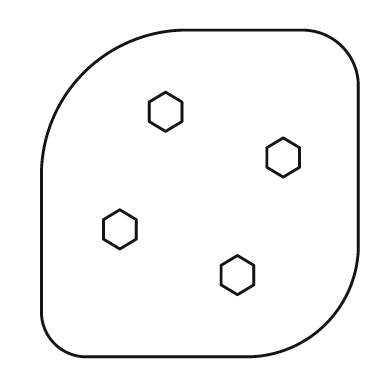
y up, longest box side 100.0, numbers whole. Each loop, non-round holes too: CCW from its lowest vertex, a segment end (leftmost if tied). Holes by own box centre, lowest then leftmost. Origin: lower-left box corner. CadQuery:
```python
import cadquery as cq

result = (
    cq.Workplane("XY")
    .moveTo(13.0, 0.0)
    .lineTo(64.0, 0.0)
    .threePointArc((87.0, 10.0), (97.0, 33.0))
    .lineTo(97.0, 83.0)
    .threePointArc((92.0, 95.0), (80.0, 100.0))
    .lineTo(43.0, 100.0)
    .threePointArc((13.0, 87.0), (0.0, 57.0))
    .lineTo(0.0, 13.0)
    .threePointArc((4.0, 4.0), (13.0, 0.0))
    .close()
    .moveTo(60.0, 19.0)
    .lineTo(65.0, 22.0)
    .lineTo(65.0, 28.0)
    .lineTo(60.0, 31.0)
    .lineTo(55.0, 28.0)
    .lineTo(55.0, 22.0)
    .close()
    .moveTo(24.0, 33.0)
    .lineTo(29.0, 36.0)
    .lineTo(29.0, 42.0)
    .lineTo(24.0, 45.0)
    .lineTo(19.0, 42.0)
    .lineTo(19.0, 36.0)
    .close()
    .moveTo(74.0, 55.0)
    .lineTo(79.0, 58.0)
    .lineTo(79.0, 64.0)
    .lineTo(74.0, 67.0)
    .lineTo(69.0, 64.0)
    .lineTo(69.0, 58.0)
    .close()
    .moveTo(38.0, 69.0)
    .lineTo(43.0, 72.0)
    .lineTo(43.0, 78.0)
    .lineTo(38.0, 81.0)
    .lineTo(33.0, 78.0)
    .lineTo(33.0, 72.0)
    .close()
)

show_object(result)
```